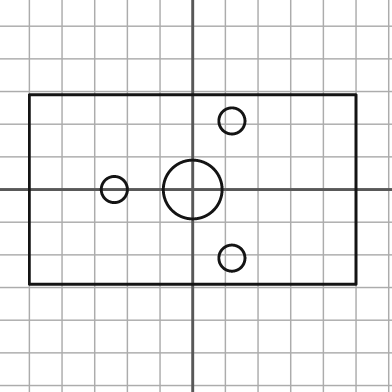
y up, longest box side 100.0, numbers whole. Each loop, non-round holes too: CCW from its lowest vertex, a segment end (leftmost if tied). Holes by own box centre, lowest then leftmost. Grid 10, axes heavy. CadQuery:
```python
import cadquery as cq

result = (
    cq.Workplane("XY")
    .moveTo(-50.0, -29.0)
    .lineTo(50.0, -29.0)
    .lineTo(50.0, 29.0)
    .lineTo(-50.0, 29.0)
    .close()
    .moveTo(12.0, -21.0)
    .circle(4.0)
    .moveTo(-24.0, 0.0)
    .circle(4.0)
    .moveTo(0.0, 0.0)
    .circle(9.0)
    .moveTo(12.0, 21.0)
    .circle(4.0)
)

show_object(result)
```